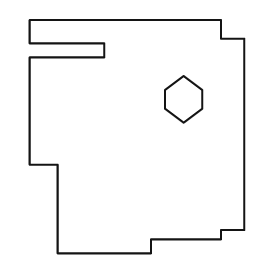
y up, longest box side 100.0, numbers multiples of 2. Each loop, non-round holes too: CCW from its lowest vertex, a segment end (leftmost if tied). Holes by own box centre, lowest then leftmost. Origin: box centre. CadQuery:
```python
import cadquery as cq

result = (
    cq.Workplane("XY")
    .moveTo(-34.0, -50.0)
    .lineTo(6.0, -50.0)
    .lineTo(6.0, -44.0)
    .lineTo(36.0, -44.0)
    .lineTo(36.0, -40.0)
    .lineTo(46.0, -40.0)
    .lineTo(46.0, 42.0)
    .lineTo(36.0, 42.0)
    .lineTo(36.0, 50.0)
    .lineTo(-46.0, 50.0)
    .lineTo(-46.0, 40.0)
    .lineTo(-14.0, 40.0)
    .lineTo(-14.0, 34.0)
    .lineTo(-46.0, 34.0)
    .lineTo(-46.0, -12.0)
    .lineTo(-34.0, -12.0)
    .close()
    .moveTo(20.0, 6.0)
    .lineTo(28.0, 12.0)
    .lineTo(28.0, 20.0)
    .lineTo(20.0, 26.0)
    .lineTo(12.0, 20.0)
    .lineTo(12.0, 12.0)
    .close()
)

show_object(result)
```